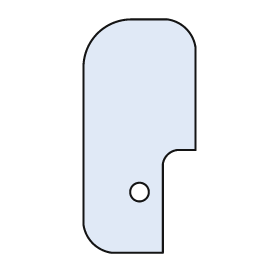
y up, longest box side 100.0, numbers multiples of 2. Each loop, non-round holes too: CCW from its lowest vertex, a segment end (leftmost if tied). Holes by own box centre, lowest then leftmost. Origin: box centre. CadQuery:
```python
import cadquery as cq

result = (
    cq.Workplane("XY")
    .moveTo(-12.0, -50.0)
    .lineTo(10.0, -50.0)
    .lineTo(10.0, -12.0)
    .threePointArc((12.0, -8.0), (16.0, -6.0))
    .lineTo(24.0, -6.0)
    .lineTo(24.0, 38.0)
    .threePointArc((20.0, 46.0), (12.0, 50.0))
    .lineTo(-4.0, 50.0)
    .threePointArc((-18.0, 44.0), (-24.0, 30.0))
    .lineTo(-24.0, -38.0)
    .threePointArc((-20.0, -46.0), (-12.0, -50.0))
    .close()
    .moveTo(0.0, -24.0)
    .circle(4.0)
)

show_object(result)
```